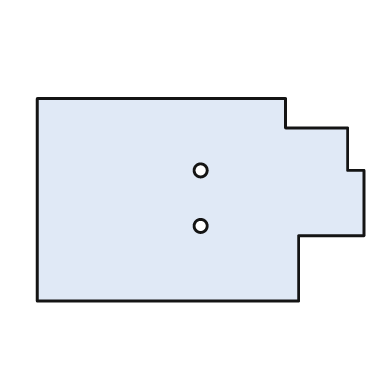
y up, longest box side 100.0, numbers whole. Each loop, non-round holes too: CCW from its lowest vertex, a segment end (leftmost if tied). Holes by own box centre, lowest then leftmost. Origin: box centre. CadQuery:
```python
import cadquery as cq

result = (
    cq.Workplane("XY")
    .moveTo(-50.0, -31.0)
    .lineTo(30.0, -31.0)
    .lineTo(30.0, -11.0)
    .lineTo(50.0, -11.0)
    .lineTo(50.0, 9.0)
    .lineTo(45.0, 9.0)
    .lineTo(45.0, 22.0)
    .lineTo(26.0, 22.0)
    .lineTo(26.0, 31.0)
    .lineTo(-50.0, 31.0)
    .close()
    .moveTo(0.0, -8.0)
    .circle(2.0)
    .moveTo(0.0, 9.0)
    .circle(2.0)
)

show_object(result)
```